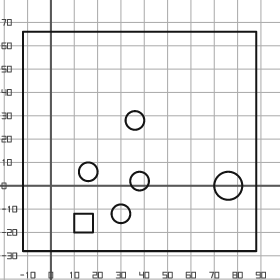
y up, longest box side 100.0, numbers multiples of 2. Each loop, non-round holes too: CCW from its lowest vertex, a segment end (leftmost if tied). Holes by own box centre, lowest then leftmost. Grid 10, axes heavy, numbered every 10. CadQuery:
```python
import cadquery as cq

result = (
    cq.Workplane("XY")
    .moveTo(-12.0, -28.0)
    .lineTo(88.0, -28.0)
    .lineTo(88.0, 66.0)
    .lineTo(-12.0, 66.0)
    .close()
    .moveTo(10.0, -20.0)
    .lineTo(18.0, -20.0)
    .lineTo(18.0, -12.0)
    .lineTo(10.0, -12.0)
    .close()
    .moveTo(30.0, -12.0)
    .circle(4.0)
    .moveTo(76.0, 0.0)
    .circle(6.0)
    .moveTo(38.0, 2.0)
    .circle(4.0)
    .moveTo(16.0, 6.0)
    .circle(4.0)
    .moveTo(36.0, 28.0)
    .circle(4.0)
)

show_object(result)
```